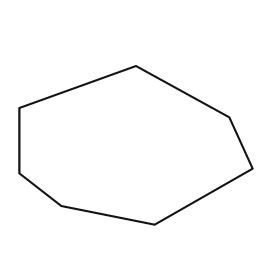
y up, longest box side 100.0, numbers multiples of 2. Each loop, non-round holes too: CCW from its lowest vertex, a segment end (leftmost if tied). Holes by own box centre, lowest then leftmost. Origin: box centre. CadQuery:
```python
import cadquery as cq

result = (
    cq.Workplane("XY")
    .moveTo(8.0, -34.0)
    .lineTo(50.0, -10.0)
    .lineTo(40.0, 12.0)
    .lineTo(0.0, 34.0)
    .lineTo(-50.0, 16.0)
    .lineTo(-50.0, -12.0)
    .lineTo(-32.0, -26.0)
    .close()
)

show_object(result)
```